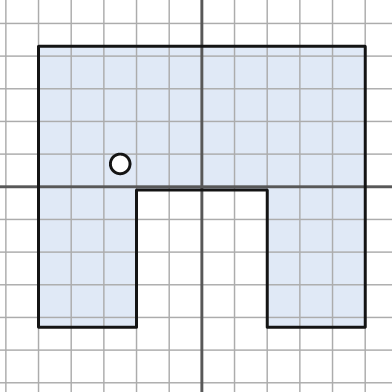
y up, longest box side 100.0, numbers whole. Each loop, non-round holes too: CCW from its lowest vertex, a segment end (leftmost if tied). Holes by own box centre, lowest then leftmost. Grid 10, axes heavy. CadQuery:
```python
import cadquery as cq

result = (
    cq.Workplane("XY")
    .moveTo(-50.0, -43.0)
    .lineTo(-20.0, -43.0)
    .lineTo(-20.0, -1.0)
    .lineTo(20.0, -1.0)
    .lineTo(20.0, -43.0)
    .lineTo(50.0, -43.0)
    .lineTo(50.0, 43.0)
    .lineTo(-50.0, 43.0)
    .close()
    .moveTo(-25.0, 7.0)
    .circle(3.0)
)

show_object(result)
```